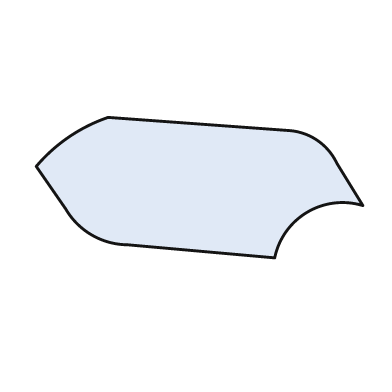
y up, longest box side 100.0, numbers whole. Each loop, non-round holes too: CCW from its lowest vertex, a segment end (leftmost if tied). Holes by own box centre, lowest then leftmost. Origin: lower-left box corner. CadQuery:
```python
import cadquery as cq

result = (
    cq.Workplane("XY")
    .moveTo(73.0, 0.0)
    .threePointArc((83.0, 14.0), (100.0, 16.0))
    .lineTo(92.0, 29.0)
    .threePointArc((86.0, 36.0), (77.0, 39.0))
    .lineTo(22.0, 43.0)
    .threePointArc((10.0, 37.0), (0.0, 28.0))
    .lineTo(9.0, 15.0)
    .threePointArc((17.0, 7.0), (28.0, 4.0))
    .close()
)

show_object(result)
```